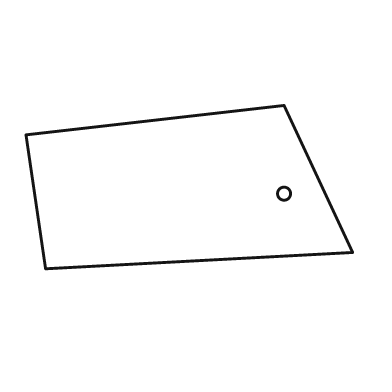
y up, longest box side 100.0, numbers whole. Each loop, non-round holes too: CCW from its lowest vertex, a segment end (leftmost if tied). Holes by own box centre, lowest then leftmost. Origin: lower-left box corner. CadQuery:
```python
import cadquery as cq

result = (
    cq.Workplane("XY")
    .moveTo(6.0, 0.0)
    .lineTo(100.0, 5.0)
    .lineTo(79.0, 50.0)
    .lineTo(0.0, 41.0)
    .close()
    .moveTo(79.0, 23.0)
    .circle(2.0)
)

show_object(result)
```